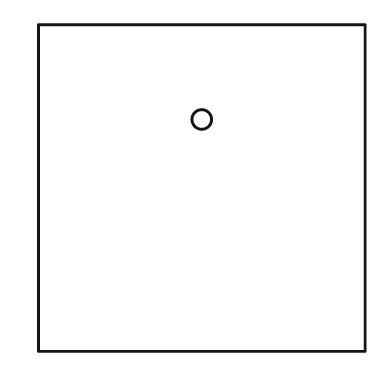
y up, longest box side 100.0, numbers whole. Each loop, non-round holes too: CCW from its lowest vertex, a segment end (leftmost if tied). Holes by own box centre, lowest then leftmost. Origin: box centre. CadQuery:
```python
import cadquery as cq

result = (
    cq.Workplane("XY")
    .moveTo(-50.0, -50.0)
    .lineTo(50.0, -50.0)
    .lineTo(50.0, 50.0)
    .lineTo(-50.0, 50.0)
    .close()
    .moveTo(0.0, 21.0)
    .circle(3.0)
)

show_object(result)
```